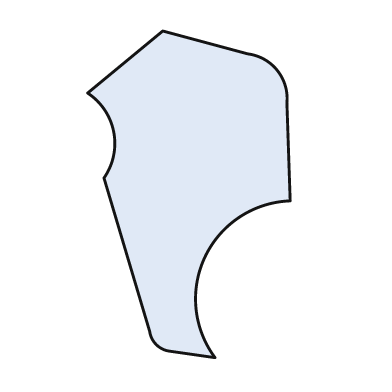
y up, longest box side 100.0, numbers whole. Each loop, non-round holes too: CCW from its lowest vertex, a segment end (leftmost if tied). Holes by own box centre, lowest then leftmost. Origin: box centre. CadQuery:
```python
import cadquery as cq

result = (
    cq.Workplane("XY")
    .moveTo(8.0, -50.0)
    .threePointArc((5.0, -19.0), (31.0, -2.0))
    .lineTo(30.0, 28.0)
    .threePointArc((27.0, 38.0), (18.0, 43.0))
    .lineTo(-8.0, 50.0)
    .lineTo(-31.0, 31.0)
    .threePointArc((-23.0, 19.0), (-26.0, 5.0))
    .lineTo(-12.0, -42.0)
    .threePointArc((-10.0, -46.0), (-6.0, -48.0))
    .close()
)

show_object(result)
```